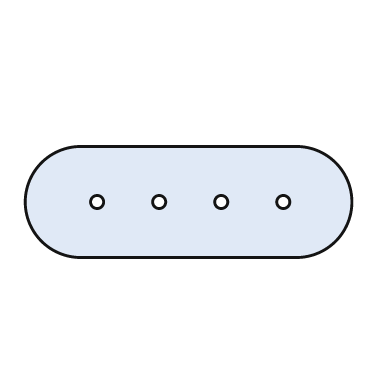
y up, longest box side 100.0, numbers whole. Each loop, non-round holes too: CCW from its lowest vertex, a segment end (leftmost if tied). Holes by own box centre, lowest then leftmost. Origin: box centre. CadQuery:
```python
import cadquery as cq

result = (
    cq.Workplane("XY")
    .moveTo(-33.0, -17.0)
    .lineTo(33.0, -17.0)
    .threePointArc((50.0, 0.0), (33.0, 17.0))
    .lineTo(-33.0, 17.0)
    .threePointArc((-50.0, 0.0), (-33.0, -17.0))
    .close()
    .moveTo(-28.0, 0.0)
    .circle(2.0)
    .moveTo(-9.0, 0.0)
    .circle(2.0)
    .moveTo(10.0, 0.0)
    .circle(2.0)
    .moveTo(29.0, 0.0)
    .circle(2.0)
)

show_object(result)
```